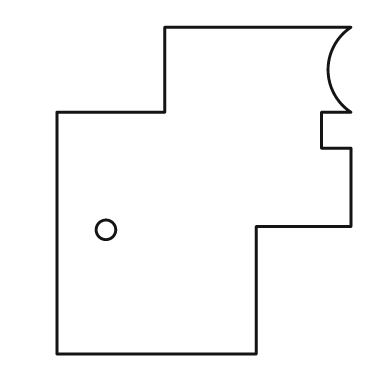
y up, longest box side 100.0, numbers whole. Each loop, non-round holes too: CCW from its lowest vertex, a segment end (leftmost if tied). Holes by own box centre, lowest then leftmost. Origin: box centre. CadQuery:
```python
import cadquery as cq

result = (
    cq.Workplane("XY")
    .moveTo(-45.0, -50.0)
    .lineTo(16.0, -50.0)
    .lineTo(16.0, -11.0)
    .lineTo(45.0, -11.0)
    .lineTo(45.0, 13.0)
    .lineTo(36.0, 13.0)
    .lineTo(36.0, 24.0)
    .lineTo(45.0, 24.0)
    .threePointArc((38.0, 37.0), (45.0, 50.0))
    .lineTo(-12.0, 50.0)
    .lineTo(-12.0, 24.0)
    .lineTo(-45.0, 24.0)
    .close()
    .moveTo(-30.0, -12.0)
    .circle(3.0)
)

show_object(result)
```